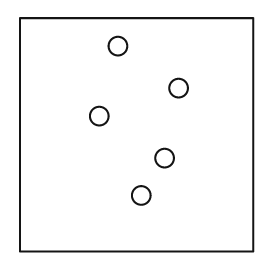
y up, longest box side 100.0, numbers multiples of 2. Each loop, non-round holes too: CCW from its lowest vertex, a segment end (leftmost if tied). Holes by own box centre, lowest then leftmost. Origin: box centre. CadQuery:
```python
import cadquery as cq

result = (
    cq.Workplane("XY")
    .moveTo(-50.0, -50.0)
    .lineTo(50.0, -50.0)
    .lineTo(50.0, 50.0)
    .lineTo(-50.0, 50.0)
    .close()
    .moveTo(2.0, -26.0)
    .circle(4.0)
    .moveTo(12.0, -10.0)
    .circle(4.0)
    .moveTo(-16.0, 8.0)
    .circle(4.0)
    .moveTo(18.0, 20.0)
    .circle(4.0)
    .moveTo(-8.0, 38.0)
    .circle(4.0)
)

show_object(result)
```